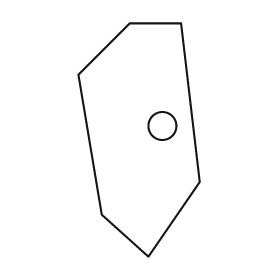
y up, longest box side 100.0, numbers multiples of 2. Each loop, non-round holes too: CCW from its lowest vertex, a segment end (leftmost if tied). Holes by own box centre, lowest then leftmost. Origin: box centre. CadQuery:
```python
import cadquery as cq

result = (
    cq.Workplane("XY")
    .moveTo(4.0, -50.0)
    .lineTo(26.0, -18.0)
    .lineTo(18.0, 50.0)
    .lineTo(-4.0, 50.0)
    .lineTo(-26.0, 28.0)
    .lineTo(-16.0, -32.0)
    .close()
    .moveTo(10.0, 6.0)
    .circle(6.0)
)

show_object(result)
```